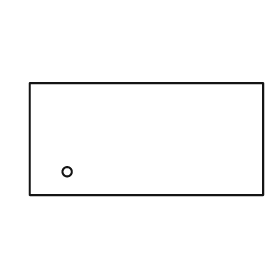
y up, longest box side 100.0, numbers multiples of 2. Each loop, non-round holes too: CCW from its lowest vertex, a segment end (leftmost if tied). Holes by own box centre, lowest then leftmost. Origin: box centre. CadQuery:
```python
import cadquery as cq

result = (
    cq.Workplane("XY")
    .moveTo(-50.0, -24.0)
    .lineTo(50.0, -24.0)
    .lineTo(50.0, 24.0)
    .lineTo(-50.0, 24.0)
    .close()
    .moveTo(-34.0, -14.0)
    .circle(2.0)
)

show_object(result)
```